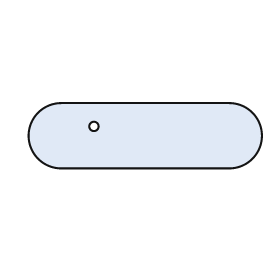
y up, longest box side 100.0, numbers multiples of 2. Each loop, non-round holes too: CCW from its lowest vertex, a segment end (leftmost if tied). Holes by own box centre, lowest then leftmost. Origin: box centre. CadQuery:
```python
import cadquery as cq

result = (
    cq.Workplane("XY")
    .moveTo(-36.0, -14.0)
    .lineTo(36.0, -14.0)
    .threePointArc((50.0, 0.0), (36.0, 14.0))
    .lineTo(-36.0, 14.0)
    .threePointArc((-50.0, 0.0), (-36.0, -14.0))
    .close()
    .moveTo(-22.0, 4.0)
    .circle(2.0)
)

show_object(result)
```